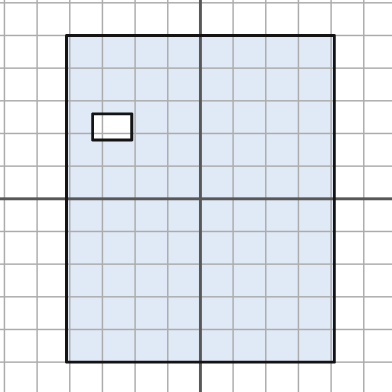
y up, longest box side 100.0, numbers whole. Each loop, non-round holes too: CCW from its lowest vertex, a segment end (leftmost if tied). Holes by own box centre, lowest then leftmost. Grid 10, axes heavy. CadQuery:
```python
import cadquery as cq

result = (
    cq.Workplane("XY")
    .moveTo(-41.0, -50.0)
    .lineTo(41.0, -50.0)
    .lineTo(41.0, 50.0)
    .lineTo(-41.0, 50.0)
    .close()
    .moveTo(-33.0, 18.0)
    .lineTo(-21.0, 18.0)
    .lineTo(-21.0, 26.0)
    .lineTo(-33.0, 26.0)
    .close()
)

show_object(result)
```